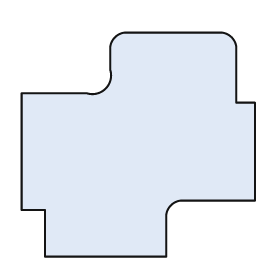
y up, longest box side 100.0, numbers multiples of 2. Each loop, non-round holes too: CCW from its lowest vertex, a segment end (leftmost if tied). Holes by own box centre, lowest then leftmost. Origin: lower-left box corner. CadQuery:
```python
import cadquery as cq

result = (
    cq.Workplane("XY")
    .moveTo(10.0, 0.0)
    .lineTo(62.0, 0.0)
    .lineTo(62.0, 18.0)
    .threePointArc((64.0, 22.0), (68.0, 24.0))
    .lineTo(100.0, 24.0)
    .lineTo(100.0, 66.0)
    .lineTo(92.0, 66.0)
    .lineTo(92.0, 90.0)
    .threePointArc((90.0, 94.0), (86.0, 96.0))
    .lineTo(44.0, 96.0)
    .threePointArc((40.0, 94.0), (38.0, 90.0))
    .lineTo(38.0, 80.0)
    .threePointArc((36.0, 72.0), (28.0, 70.0))
    .lineTo(0.0, 70.0)
    .lineTo(0.0, 20.0)
    .lineTo(10.0, 20.0)
    .close()
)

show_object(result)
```